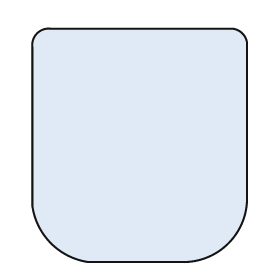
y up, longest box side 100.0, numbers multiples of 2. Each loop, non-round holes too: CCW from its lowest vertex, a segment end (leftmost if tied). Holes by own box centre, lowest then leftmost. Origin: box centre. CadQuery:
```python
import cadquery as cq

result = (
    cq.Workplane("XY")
    .moveTo(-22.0, -50.0)
    .lineTo(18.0, -50.0)
    .threePointArc((38.0, -42.0), (46.0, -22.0))
    .lineTo(46.0, 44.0)
    .threePointArc((44.0, 48.0), (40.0, 50.0))
    .lineTo(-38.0, 50.0)
    .threePointArc((-44.0, 48.0), (-46.0, 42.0))
    .lineTo(-46.0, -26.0)
    .threePointArc((-38.0, -42.0), (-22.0, -50.0))
    .close()
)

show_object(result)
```